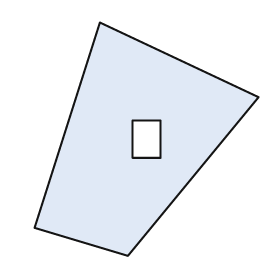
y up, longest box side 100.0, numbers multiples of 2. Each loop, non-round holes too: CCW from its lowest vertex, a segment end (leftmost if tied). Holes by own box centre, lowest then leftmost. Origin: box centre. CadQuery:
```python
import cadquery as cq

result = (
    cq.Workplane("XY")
    .moveTo(-8.0, -50.0)
    .lineTo(48.0, 18.0)
    .lineTo(-20.0, 50.0)
    .lineTo(-48.0, -38.0)
    .close()
    .moveTo(-6.0, -8.0)
    .lineTo(6.0, -8.0)
    .lineTo(6.0, 8.0)
    .lineTo(-6.0, 8.0)
    .close()
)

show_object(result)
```